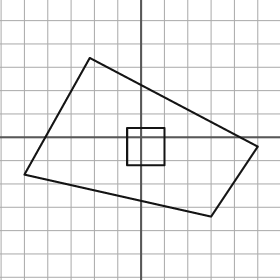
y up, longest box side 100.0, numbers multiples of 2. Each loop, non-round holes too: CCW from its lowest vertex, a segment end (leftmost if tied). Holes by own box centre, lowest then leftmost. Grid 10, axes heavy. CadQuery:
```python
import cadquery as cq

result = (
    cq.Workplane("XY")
    .moveTo(30.0, -34.0)
    .lineTo(50.0, -4.0)
    .lineTo(-22.0, 34.0)
    .lineTo(-50.0, -16.0)
    .close()
    .moveTo(-6.0, -12.0)
    .lineTo(10.0, -12.0)
    .lineTo(10.0, 4.0)
    .lineTo(-6.0, 4.0)
    .close()
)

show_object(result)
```